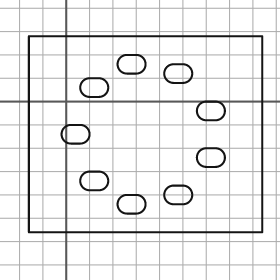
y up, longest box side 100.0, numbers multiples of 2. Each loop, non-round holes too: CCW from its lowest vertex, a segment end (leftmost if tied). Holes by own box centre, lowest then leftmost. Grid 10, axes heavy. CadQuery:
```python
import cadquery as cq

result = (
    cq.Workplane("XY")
    .moveTo(-16.0, -56.0)
    .lineTo(84.0, -56.0)
    .lineTo(84.0, 28.0)
    .lineTo(-16.0, 28.0)
    .close()
    .moveTo(26.0, -48.0)
    .lineTo(30.0, -48.0)
    .threePointArc((34.0, -44.0), (30.0, -40.0))
    .lineTo(26.0, -40.0)
    .threePointArc((22.0, -44.0), (26.0, -48.0))
    .close()
    .moveTo(46.0, -44.0)
    .lineTo(50.0, -44.0)
    .threePointArc((54.0, -40.0), (50.0, -36.0))
    .lineTo(46.0, -36.0)
    .threePointArc((42.0, -40.0), (46.0, -44.0))
    .close()
    .moveTo(10.0, -38.0)
    .lineTo(14.0, -38.0)
    .threePointArc((18.0, -34.0), (14.0, -30.0))
    .lineTo(10.0, -30.0)
    .threePointArc((6.0, -34.0), (10.0, -38.0))
    .close()
    .moveTo(60.0, -28.0)
    .lineTo(64.0, -28.0)
    .threePointArc((68.0, -24.0), (64.0, -20.0))
    .lineTo(60.0, -20.0)
    .threePointArc((56.0, -24.0), (60.0, -28.0))
    .close()
    .moveTo(2.0, -18.0)
    .lineTo(6.0, -18.0)
    .threePointArc((10.0, -14.0), (6.0, -10.0))
    .lineTo(2.0, -10.0)
    .threePointArc((-2.0, -14.0), (2.0, -18.0))
    .close()
    .moveTo(60.0, -8.0)
    .lineTo(64.0, -8.0)
    .threePointArc((68.0, -4.0), (64.0, 0.0))
    .lineTo(60.0, 0.0)
    .threePointArc((56.0, -4.0), (60.0, -8.0))
    .close()
    .moveTo(10.0, 2.0)
    .lineTo(14.0, 2.0)
    .threePointArc((18.0, 6.0), (14.0, 10.0))
    .lineTo(10.0, 10.0)
    .threePointArc((6.0, 6.0), (10.0, 2.0))
    .close()
    .moveTo(46.0, 8.0)
    .lineTo(50.0, 8.0)
    .threePointArc((54.0, 12.0), (50.0, 16.0))
    .lineTo(46.0, 16.0)
    .threePointArc((42.0, 12.0), (46.0, 8.0))
    .close()
    .moveTo(26.0, 12.0)
    .lineTo(30.0, 12.0)
    .threePointArc((34.0, 16.0), (30.0, 20.0))
    .lineTo(26.0, 20.0)
    .threePointArc((22.0, 16.0), (26.0, 12.0))
    .close()
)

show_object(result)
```